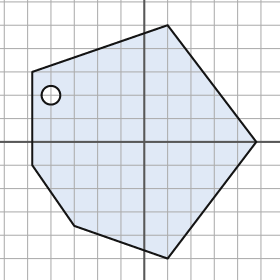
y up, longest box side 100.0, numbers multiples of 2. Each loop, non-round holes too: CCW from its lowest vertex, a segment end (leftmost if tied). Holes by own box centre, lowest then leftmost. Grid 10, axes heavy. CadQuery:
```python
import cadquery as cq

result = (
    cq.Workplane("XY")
    .moveTo(10.0, -50.0)
    .lineTo(48.0, 0.0)
    .lineTo(10.0, 50.0)
    .lineTo(-48.0, 30.0)
    .lineTo(-48.0, -10.0)
    .lineTo(-30.0, -36.0)
    .close()
    .moveTo(-40.0, 20.0)
    .circle(4.0)
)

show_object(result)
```